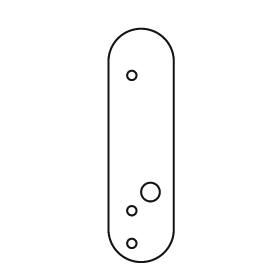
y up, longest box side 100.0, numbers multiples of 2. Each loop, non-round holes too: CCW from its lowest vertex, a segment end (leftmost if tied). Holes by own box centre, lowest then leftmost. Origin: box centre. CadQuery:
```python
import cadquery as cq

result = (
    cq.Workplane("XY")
    .moveTo(-14.0, -36.0)
    .threePointArc((0.0, -50.0), (14.0, -36.0))
    .lineTo(14.0, 36.0)
    .threePointArc((0.0, 50.0), (-14.0, 36.0))
    .close()
    .moveTo(-4.0, -42.0)
    .circle(2.0)
    .moveTo(-4.0, -28.0)
    .circle(2.0)
    .moveTo(4.0, -20.0)
    .circle(4.0)
    .moveTo(-4.0, 30.0)
    .circle(2.0)
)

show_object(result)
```